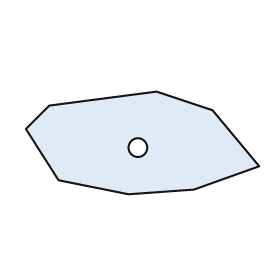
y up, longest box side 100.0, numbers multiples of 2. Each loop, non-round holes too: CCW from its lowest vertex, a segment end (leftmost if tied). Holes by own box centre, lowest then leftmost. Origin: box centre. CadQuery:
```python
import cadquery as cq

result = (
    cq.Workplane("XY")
    .moveTo(-6.0, -22.0)
    .lineTo(22.0, -20.0)
    .lineTo(50.0, -10.0)
    .lineTo(30.0, 14.0)
    .lineTo(6.0, 22.0)
    .lineTo(-40.0, 16.0)
    .lineTo(-50.0, 6.0)
    .lineTo(-36.0, -16.0)
    .close()
    .moveTo(-2.0, -2.0)
    .circle(4.0)
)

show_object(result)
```